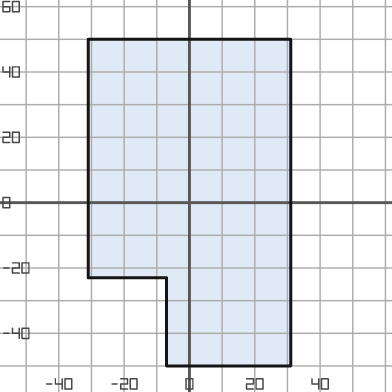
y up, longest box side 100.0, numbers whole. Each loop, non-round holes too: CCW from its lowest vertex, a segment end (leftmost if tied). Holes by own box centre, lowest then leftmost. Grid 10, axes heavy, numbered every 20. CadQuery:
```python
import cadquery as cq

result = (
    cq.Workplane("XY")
    .moveTo(-7.0, -50.0)
    .lineTo(31.0, -50.0)
    .lineTo(31.0, 50.0)
    .lineTo(-31.0, 50.0)
    .lineTo(-31.0, -23.0)
    .lineTo(-7.0, -23.0)
    .close()
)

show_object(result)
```